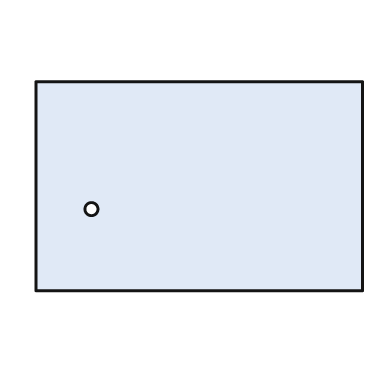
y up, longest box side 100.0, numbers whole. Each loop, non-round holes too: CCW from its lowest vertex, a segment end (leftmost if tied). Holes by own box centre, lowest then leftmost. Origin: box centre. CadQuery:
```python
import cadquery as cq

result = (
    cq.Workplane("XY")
    .moveTo(-50.0, -32.0)
    .lineTo(50.0, -32.0)
    .lineTo(50.0, 32.0)
    .lineTo(-50.0, 32.0)
    .close()
    .moveTo(-33.0, -7.0)
    .circle(2.0)
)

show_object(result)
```